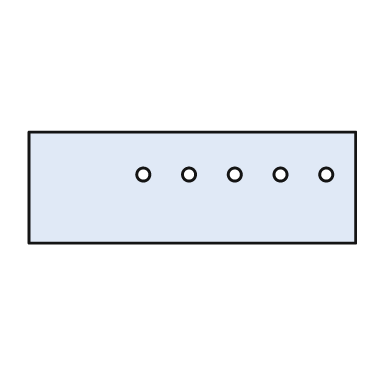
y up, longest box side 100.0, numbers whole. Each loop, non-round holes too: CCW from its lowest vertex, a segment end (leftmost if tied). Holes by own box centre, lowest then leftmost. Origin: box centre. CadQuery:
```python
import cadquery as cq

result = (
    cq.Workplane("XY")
    .moveTo(-50.0, -17.0)
    .lineTo(50.0, -17.0)
    .lineTo(50.0, 17.0)
    .lineTo(-50.0, 17.0)
    .close()
    .moveTo(-15.0, 4.0)
    .circle(2.0)
    .moveTo(-1.0, 4.0)
    .circle(2.0)
    .moveTo(13.0, 4.0)
    .circle(2.0)
    .moveTo(27.0, 4.0)
    .circle(2.0)
    .moveTo(41.0, 4.0)
    .circle(2.0)
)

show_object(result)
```